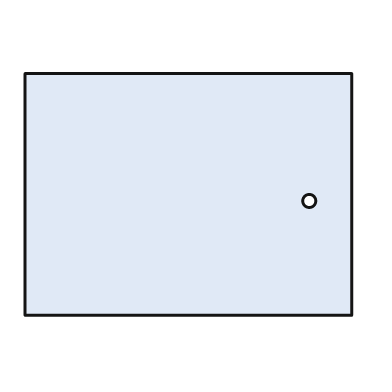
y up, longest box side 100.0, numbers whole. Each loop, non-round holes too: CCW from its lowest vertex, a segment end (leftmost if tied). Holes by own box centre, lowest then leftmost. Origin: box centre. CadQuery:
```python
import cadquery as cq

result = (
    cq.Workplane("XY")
    .moveTo(-50.0, -37.0)
    .lineTo(50.0, -37.0)
    .lineTo(50.0, 37.0)
    .lineTo(-50.0, 37.0)
    .close()
    .moveTo(37.0, -2.0)
    .circle(2.0)
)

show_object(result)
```